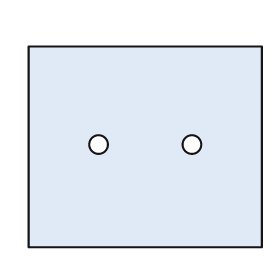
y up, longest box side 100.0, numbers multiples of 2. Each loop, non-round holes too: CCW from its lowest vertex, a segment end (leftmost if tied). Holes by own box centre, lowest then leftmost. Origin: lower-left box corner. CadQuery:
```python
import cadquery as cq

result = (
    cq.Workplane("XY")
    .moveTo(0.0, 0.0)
    .lineTo(100.0, 0.0)
    .lineTo(100.0, 86.0)
    .lineTo(0.0, 86.0)
    .close()
    .moveTo(30.0, 44.0)
    .circle(4.0)
    .moveTo(70.0, 44.0)
    .circle(4.0)
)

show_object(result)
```